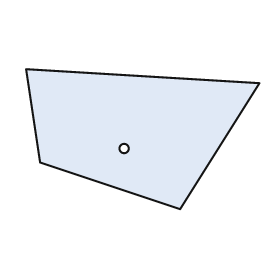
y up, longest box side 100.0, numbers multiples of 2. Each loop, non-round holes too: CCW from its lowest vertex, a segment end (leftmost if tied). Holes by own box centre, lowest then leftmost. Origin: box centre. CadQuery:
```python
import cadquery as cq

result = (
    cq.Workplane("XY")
    .moveTo(16.0, -30.0)
    .lineTo(50.0, 24.0)
    .lineTo(-50.0, 30.0)
    .lineTo(-44.0, -10.0)
    .close()
    .moveTo(-8.0, -4.0)
    .circle(2.0)
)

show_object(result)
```